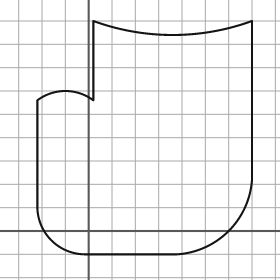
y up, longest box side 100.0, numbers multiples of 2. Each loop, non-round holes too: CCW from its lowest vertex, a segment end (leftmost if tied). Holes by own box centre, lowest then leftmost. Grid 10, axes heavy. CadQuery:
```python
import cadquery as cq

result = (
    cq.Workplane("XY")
    .moveTo(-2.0, -10.0)
    .lineTo(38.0, -10.0)
    .threePointArc((60.0, 0.0), (70.0, 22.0))
    .lineTo(70.0, 90.0)
    .threePointArc((36.0, 84.0), (2.0, 90.0))
    .lineTo(2.0, 56.0)
    .threePointArc((-10.0, 60.0), (-22.0, 56.0))
    .lineTo(-22.0, 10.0)
    .threePointArc((-16.0, -4.0), (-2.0, -10.0))
    .close()
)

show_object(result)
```